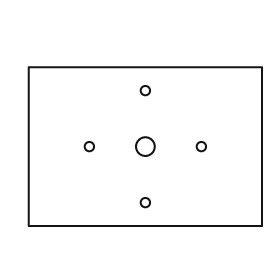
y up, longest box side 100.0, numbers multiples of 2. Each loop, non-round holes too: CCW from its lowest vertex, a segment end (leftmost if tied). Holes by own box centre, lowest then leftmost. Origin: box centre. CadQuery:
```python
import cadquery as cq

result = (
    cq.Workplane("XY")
    .moveTo(-50.0, -34.0)
    .lineTo(50.0, -34.0)
    .lineTo(50.0, 34.0)
    .lineTo(-50.0, 34.0)
    .close()
    .moveTo(0.0, -24.0)
    .circle(2.0)
    .moveTo(-24.0, 0.0)
    .circle(2.0)
    .moveTo(0.0, 0.0)
    .circle(4.0)
    .moveTo(24.0, 0.0)
    .circle(2.0)
    .moveTo(0.0, 24.0)
    .circle(2.0)
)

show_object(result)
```